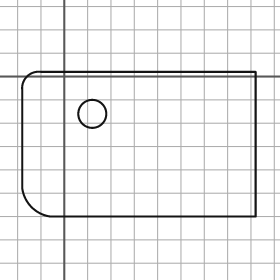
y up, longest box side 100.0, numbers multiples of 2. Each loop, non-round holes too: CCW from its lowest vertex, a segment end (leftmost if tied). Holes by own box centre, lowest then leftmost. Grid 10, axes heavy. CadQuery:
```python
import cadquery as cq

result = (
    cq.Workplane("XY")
    .moveTo(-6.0, -60.0)
    .lineTo(82.0, -60.0)
    .lineTo(82.0, 2.0)
    .lineTo(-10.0, 2.0)
    .threePointArc((-16.0, 0.0), (-18.0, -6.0))
    .lineTo(-18.0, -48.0)
    .threePointArc((-14.0, -56.0), (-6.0, -60.0))
    .close()
    .moveTo(12.0, -16.0)
    .circle(6.0)
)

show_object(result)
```